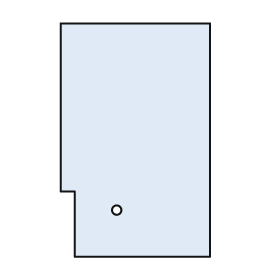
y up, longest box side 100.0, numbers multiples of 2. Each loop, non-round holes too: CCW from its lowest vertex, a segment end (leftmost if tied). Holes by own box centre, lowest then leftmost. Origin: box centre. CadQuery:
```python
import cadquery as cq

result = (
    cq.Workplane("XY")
    .moveTo(-26.0, -50.0)
    .lineTo(32.0, -50.0)
    .lineTo(32.0, 50.0)
    .lineTo(-32.0, 50.0)
    .lineTo(-32.0, -22.0)
    .lineTo(-26.0, -22.0)
    .close()
    .moveTo(-8.0, -30.0)
    .circle(2.0)
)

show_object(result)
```